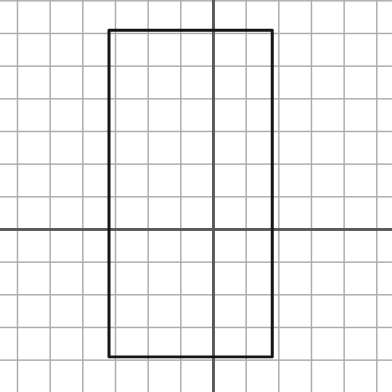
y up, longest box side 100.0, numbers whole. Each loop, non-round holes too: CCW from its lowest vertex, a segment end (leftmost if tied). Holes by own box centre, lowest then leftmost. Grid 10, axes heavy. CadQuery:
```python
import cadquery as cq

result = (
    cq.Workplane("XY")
    .moveTo(-32.0, -39.0)
    .lineTo(18.0, -39.0)
    .lineTo(18.0, 61.0)
    .lineTo(-32.0, 61.0)
    .close()
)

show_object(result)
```